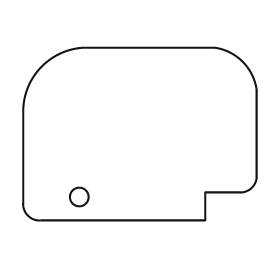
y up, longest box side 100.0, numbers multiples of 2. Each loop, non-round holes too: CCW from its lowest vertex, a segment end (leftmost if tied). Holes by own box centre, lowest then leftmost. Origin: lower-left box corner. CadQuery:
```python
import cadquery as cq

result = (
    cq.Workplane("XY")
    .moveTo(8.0, 0.0)
    .lineTo(78.0, 0.0)
    .lineTo(78.0, 12.0)
    .lineTo(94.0, 12.0)
    .threePointArc((98.0, 14.0), (100.0, 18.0))
    .lineTo(100.0, 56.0)
    .threePointArc((94.0, 68.0), (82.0, 74.0))
    .lineTo(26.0, 74.0)
    .threePointArc((8.0, 66.0), (0.0, 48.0))
    .lineTo(0.0, 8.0)
    .threePointArc((2.0, 2.0), (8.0, 0.0))
    .close()
    .moveTo(24.0, 10.0)
    .circle(4.0)
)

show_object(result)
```